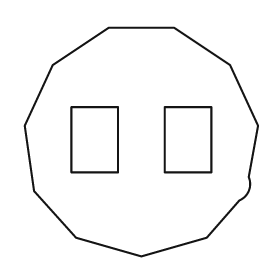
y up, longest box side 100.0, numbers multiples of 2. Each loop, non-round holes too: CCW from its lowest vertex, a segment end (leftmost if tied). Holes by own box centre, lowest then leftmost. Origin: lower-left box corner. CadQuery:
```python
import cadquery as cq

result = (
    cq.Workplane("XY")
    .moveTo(50.0, 0.0)
    .lineTo(78.0, 8.0)
    .lineTo(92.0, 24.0)
    .threePointArc((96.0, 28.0), (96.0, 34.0))
    .lineTo(100.0, 56.0)
    .lineTo(88.0, 82.0)
    .lineTo(64.0, 98.0)
    .lineTo(36.0, 98.0)
    .lineTo(12.0, 82.0)
    .lineTo(0.0, 56.0)
    .lineTo(4.0, 28.0)
    .lineTo(22.0, 8.0)
    .close()
    .moveTo(20.0, 36.0)
    .lineTo(40.0, 36.0)
    .lineTo(40.0, 64.0)
    .lineTo(20.0, 64.0)
    .close()
    .moveTo(60.0, 36.0)
    .lineTo(80.0, 36.0)
    .lineTo(80.0, 64.0)
    .lineTo(60.0, 64.0)
    .close()
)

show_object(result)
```